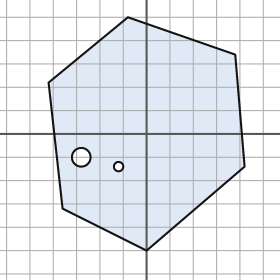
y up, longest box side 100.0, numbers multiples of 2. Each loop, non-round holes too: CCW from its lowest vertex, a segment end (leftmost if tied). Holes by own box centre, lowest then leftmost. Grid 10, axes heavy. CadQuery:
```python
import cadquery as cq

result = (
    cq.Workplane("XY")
    .moveTo(0.0, -50.0)
    .lineTo(42.0, -14.0)
    .lineTo(38.0, 34.0)
    .lineTo(-8.0, 50.0)
    .lineTo(-42.0, 22.0)
    .lineTo(-36.0, -32.0)
    .close()
    .moveTo(-12.0, -14.0)
    .circle(2.0)
    .moveTo(-28.0, -10.0)
    .circle(4.0)
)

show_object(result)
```